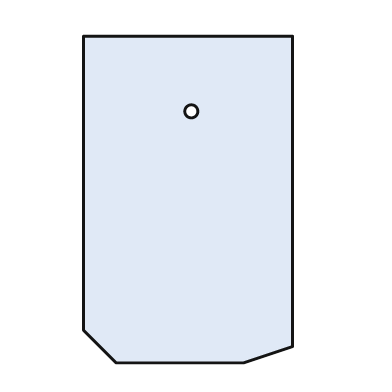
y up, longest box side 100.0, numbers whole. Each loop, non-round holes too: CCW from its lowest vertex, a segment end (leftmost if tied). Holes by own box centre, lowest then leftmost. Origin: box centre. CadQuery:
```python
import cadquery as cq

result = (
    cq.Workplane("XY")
    .moveTo(-22.0, -50.0)
    .lineTo(17.0, -50.0)
    .lineTo(32.0, -45.0)
    .lineTo(32.0, 50.0)
    .lineTo(-32.0, 50.0)
    .lineTo(-32.0, -40.0)
    .close()
    .moveTo(1.0, 27.0)
    .circle(2.0)
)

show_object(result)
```